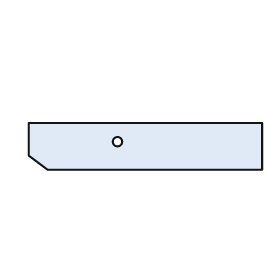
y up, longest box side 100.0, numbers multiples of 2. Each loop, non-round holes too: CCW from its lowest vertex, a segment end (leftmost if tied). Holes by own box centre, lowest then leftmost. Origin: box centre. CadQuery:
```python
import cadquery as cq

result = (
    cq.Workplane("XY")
    .moveTo(-42.0, -10.0)
    .lineTo(50.0, -10.0)
    .lineTo(50.0, 10.0)
    .lineTo(-50.0, 10.0)
    .lineTo(-50.0, -4.0)
    .close()
    .moveTo(-12.0, 2.0)
    .circle(2.0)
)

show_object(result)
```